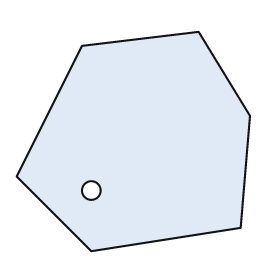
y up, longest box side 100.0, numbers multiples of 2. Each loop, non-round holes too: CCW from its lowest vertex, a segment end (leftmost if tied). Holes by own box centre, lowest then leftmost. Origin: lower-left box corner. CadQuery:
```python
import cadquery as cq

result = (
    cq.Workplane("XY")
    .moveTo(32.0, 0.0)
    .lineTo(96.0, 10.0)
    .lineTo(100.0, 58.0)
    .lineTo(78.0, 94.0)
    .lineTo(28.0, 88.0)
    .lineTo(0.0, 32.0)
    .close()
    .moveTo(32.0, 26.0)
    .circle(4.0)
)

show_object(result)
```